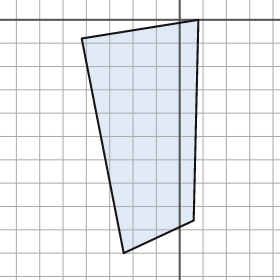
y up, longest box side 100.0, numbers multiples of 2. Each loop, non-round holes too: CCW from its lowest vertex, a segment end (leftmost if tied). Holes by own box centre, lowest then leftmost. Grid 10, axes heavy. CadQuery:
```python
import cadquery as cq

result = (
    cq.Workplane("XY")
    .moveTo(-24.0, -100.0)
    .lineTo(6.0, -86.0)
    .lineTo(8.0, 0.0)
    .lineTo(-42.0, -8.0)
    .close()
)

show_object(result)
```